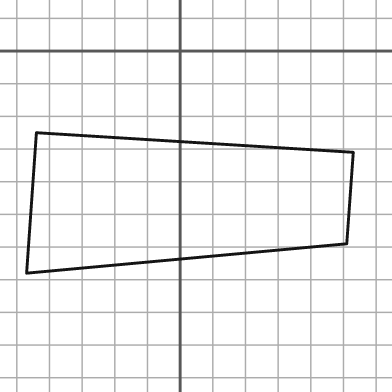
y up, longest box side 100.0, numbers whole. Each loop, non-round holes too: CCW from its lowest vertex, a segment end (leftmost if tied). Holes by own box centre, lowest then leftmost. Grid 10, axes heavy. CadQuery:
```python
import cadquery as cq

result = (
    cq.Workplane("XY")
    .moveTo(-47.0, -68.0)
    .lineTo(51.0, -59.0)
    .lineTo(53.0, -31.0)
    .lineTo(-44.0, -25.0)
    .close()
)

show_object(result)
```